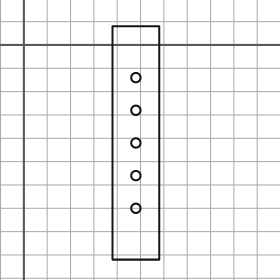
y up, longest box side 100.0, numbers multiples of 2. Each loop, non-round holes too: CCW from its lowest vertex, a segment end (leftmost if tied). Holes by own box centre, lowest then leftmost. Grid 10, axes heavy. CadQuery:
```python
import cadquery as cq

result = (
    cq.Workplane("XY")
    .moveTo(38.0, -92.0)
    .lineTo(58.0, -92.0)
    .lineTo(58.0, 8.0)
    .lineTo(38.0, 8.0)
    .close()
    .moveTo(48.0, -70.0)
    .circle(2.0)
    .moveTo(48.0, -56.0)
    .circle(2.0)
    .moveTo(48.0, -42.0)
    .circle(2.0)
    .moveTo(48.0, -28.0)
    .circle(2.0)
    .moveTo(48.0, -14.0)
    .circle(2.0)
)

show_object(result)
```